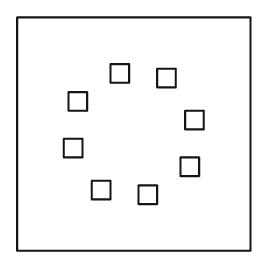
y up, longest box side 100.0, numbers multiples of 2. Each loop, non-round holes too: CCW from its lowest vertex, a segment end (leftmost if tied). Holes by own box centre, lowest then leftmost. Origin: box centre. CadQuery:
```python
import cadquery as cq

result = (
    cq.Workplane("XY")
    .moveTo(-50.0, -50.0)
    .lineTo(50.0, -50.0)
    .lineTo(50.0, 50.0)
    .lineTo(-50.0, 50.0)
    .close()
    .moveTo(2.0, -30.0)
    .lineTo(10.0, -30.0)
    .lineTo(10.0, -22.0)
    .lineTo(2.0, -22.0)
    .close()
    .moveTo(-18.0, -28.0)
    .lineTo(-10.0, -28.0)
    .lineTo(-10.0, -20.0)
    .lineTo(-18.0, -20.0)
    .close()
    .moveTo(20.0, -18.0)
    .lineTo(28.0, -18.0)
    .lineTo(28.0, -10.0)
    .lineTo(20.0, -10.0)
    .close()
    .moveTo(-30.0, -10.0)
    .lineTo(-22.0, -10.0)
    .lineTo(-22.0, -2.0)
    .lineTo(-30.0, -2.0)
    .close()
    .moveTo(22.0, 2.0)
    .lineTo(30.0, 2.0)
    .lineTo(30.0, 10.0)
    .lineTo(22.0, 10.0)
    .close()
    .moveTo(-28.0, 10.0)
    .lineTo(-20.0, 10.0)
    .lineTo(-20.0, 18.0)
    .lineTo(-28.0, 18.0)
    .close()
    .moveTo(10.0, 20.0)
    .lineTo(18.0, 20.0)
    .lineTo(18.0, 28.0)
    .lineTo(10.0, 28.0)
    .close()
    .moveTo(-10.0, 22.0)
    .lineTo(-2.0, 22.0)
    .lineTo(-2.0, 30.0)
    .lineTo(-10.0, 30.0)
    .close()
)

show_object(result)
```